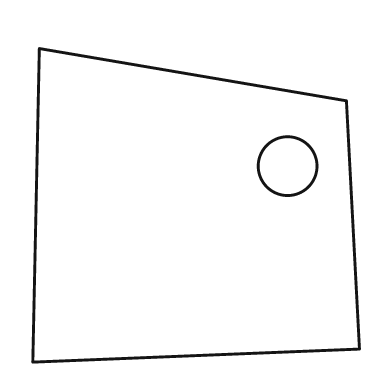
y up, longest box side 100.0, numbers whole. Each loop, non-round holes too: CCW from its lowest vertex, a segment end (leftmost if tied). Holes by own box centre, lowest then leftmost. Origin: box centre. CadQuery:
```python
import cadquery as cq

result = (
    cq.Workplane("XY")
    .moveTo(-50.0, -48.0)
    .lineTo(50.0, -44.0)
    .lineTo(46.0, 32.0)
    .lineTo(-48.0, 48.0)
    .close()
    .moveTo(28.0, 12.0)
    .circle(9.0)
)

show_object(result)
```